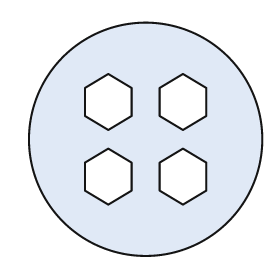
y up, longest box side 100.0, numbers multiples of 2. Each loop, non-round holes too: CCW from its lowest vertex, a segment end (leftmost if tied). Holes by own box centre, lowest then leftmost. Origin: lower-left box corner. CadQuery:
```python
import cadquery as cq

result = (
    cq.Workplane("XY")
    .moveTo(50.0, 50.0)
    .circle(50.0)
    .moveTo(34.0, 22.0)
    .lineTo(44.0, 28.0)
    .lineTo(44.0, 40.0)
    .lineTo(34.0, 46.0)
    .lineTo(24.0, 40.0)
    .lineTo(24.0, 28.0)
    .close()
    .moveTo(66.0, 22.0)
    .lineTo(76.0, 28.0)
    .lineTo(76.0, 40.0)
    .lineTo(66.0, 46.0)
    .lineTo(56.0, 40.0)
    .lineTo(56.0, 28.0)
    .close()
    .moveTo(34.0, 54.0)
    .lineTo(44.0, 60.0)
    .lineTo(44.0, 72.0)
    .lineTo(34.0, 78.0)
    .lineTo(24.0, 72.0)
    .lineTo(24.0, 60.0)
    .close()
    .moveTo(66.0, 54.0)
    .lineTo(76.0, 60.0)
    .lineTo(76.0, 72.0)
    .lineTo(66.0, 78.0)
    .lineTo(56.0, 72.0)
    .lineTo(56.0, 60.0)
    .close()
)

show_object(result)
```